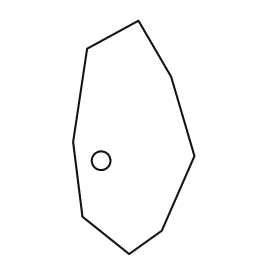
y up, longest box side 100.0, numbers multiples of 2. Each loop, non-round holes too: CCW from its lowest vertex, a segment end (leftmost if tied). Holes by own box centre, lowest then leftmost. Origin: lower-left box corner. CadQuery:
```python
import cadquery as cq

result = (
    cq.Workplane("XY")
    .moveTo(24.0, 0.0)
    .lineTo(38.0, 10.0)
    .lineTo(52.0, 42.0)
    .lineTo(42.0, 76.0)
    .lineTo(28.0, 100.0)
    .lineTo(6.0, 88.0)
    .lineTo(0.0, 48.0)
    .lineTo(4.0, 16.0)
    .close()
    .moveTo(12.0, 40.0)
    .circle(4.0)
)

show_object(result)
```